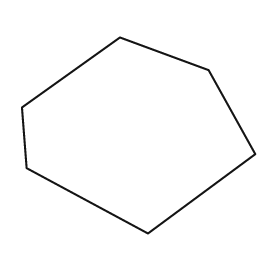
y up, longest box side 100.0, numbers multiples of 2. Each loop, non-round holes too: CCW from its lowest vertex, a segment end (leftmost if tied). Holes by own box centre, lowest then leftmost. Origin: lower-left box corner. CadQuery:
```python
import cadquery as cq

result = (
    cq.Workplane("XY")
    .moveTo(54.0, 0.0)
    .lineTo(100.0, 34.0)
    .lineTo(80.0, 70.0)
    .lineTo(42.0, 84.0)
    .lineTo(0.0, 54.0)
    .lineTo(2.0, 28.0)
    .close()
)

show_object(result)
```